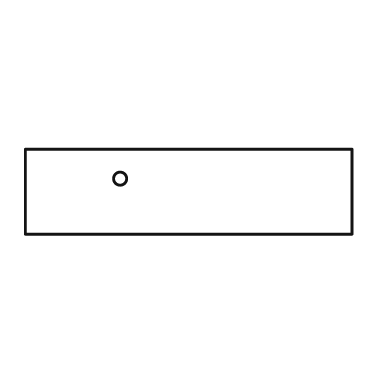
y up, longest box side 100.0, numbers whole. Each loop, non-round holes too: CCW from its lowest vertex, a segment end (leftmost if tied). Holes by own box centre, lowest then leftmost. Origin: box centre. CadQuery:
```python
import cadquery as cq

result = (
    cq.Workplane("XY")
    .moveTo(-50.0, -13.0)
    .lineTo(50.0, -13.0)
    .lineTo(50.0, 13.0)
    .lineTo(-50.0, 13.0)
    .close()
    .moveTo(-21.0, 4.0)
    .circle(2.0)
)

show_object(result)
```